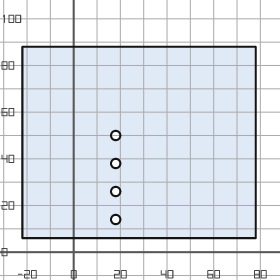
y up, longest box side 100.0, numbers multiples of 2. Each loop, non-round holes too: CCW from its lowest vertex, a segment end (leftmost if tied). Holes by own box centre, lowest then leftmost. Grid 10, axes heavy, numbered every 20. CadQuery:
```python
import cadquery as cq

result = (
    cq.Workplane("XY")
    .moveTo(-22.0, 6.0)
    .lineTo(78.0, 6.0)
    .lineTo(78.0, 88.0)
    .lineTo(-22.0, 88.0)
    .close()
    .moveTo(18.0, 14.0)
    .circle(2.0)
    .moveTo(18.0, 26.0)
    .circle(2.0)
    .moveTo(18.0, 38.0)
    .circle(2.0)
    .moveTo(18.0, 50.0)
    .circle(2.0)
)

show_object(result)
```